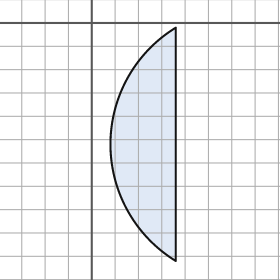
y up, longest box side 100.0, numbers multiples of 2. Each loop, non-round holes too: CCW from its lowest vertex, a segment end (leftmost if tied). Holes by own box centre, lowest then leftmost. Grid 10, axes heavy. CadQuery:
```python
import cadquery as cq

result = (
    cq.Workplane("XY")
    .moveTo(36.0, -102.0)
    .lineTo(36.0, -2.0)
    .threePointArc((8.0, -52.0), (36.0, -102.0))
    .close()
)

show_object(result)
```